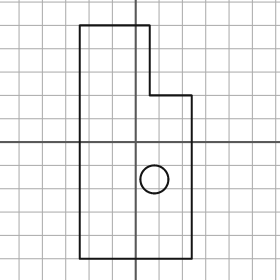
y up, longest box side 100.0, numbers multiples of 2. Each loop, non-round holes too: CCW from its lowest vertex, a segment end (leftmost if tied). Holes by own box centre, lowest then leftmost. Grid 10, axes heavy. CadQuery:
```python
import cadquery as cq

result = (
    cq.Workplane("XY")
    .moveTo(-24.0, -50.0)
    .lineTo(24.0, -50.0)
    .lineTo(24.0, 20.0)
    .lineTo(6.0, 20.0)
    .lineTo(6.0, 50.0)
    .lineTo(-24.0, 50.0)
    .close()
    .moveTo(8.0, -16.0)
    .circle(6.0)
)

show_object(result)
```